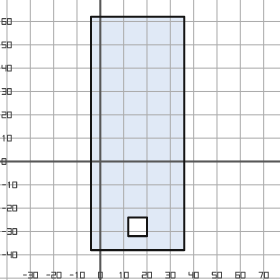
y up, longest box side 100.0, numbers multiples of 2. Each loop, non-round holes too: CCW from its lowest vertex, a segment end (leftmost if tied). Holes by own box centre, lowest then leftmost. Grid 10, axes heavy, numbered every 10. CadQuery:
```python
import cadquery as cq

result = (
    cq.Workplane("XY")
    .moveTo(-4.0, -38.0)
    .lineTo(36.0, -38.0)
    .lineTo(36.0, 62.0)
    .lineTo(-4.0, 62.0)
    .close()
    .moveTo(12.0, -32.0)
    .lineTo(20.0, -32.0)
    .lineTo(20.0, -24.0)
    .lineTo(12.0, -24.0)
    .close()
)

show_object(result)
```